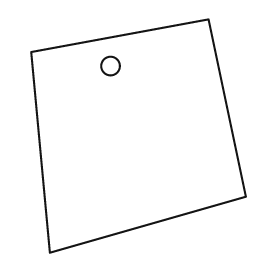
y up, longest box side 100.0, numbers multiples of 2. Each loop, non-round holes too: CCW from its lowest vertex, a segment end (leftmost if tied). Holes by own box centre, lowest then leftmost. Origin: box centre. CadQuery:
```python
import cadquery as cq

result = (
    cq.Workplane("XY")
    .moveTo(-38.0, -50.0)
    .lineTo(46.0, -26.0)
    .lineTo(30.0, 50.0)
    .lineTo(-46.0, 36.0)
    .close()
    .moveTo(-12.0, 30.0)
    .circle(4.0)
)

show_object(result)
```